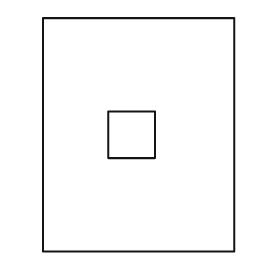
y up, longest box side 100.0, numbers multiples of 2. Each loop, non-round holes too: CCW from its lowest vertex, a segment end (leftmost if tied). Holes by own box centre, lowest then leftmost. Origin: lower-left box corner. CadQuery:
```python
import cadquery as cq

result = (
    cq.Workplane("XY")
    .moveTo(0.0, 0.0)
    .lineTo(82.0, 0.0)
    .lineTo(82.0, 100.0)
    .lineTo(0.0, 100.0)
    .close()
    .moveTo(28.0, 40.0)
    .lineTo(48.0, 40.0)
    .lineTo(48.0, 60.0)
    .lineTo(28.0, 60.0)
    .close()
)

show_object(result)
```